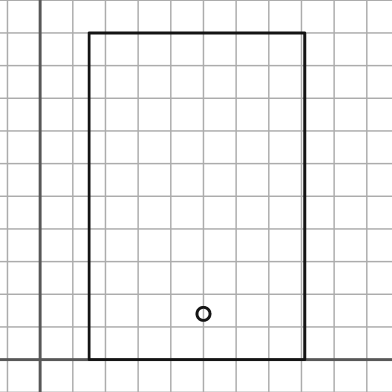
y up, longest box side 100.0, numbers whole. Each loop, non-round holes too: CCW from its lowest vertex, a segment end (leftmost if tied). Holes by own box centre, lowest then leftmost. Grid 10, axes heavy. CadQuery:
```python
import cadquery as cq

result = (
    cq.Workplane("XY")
    .moveTo(15.0, 0.0)
    .lineTo(81.0, 0.0)
    .lineTo(81.0, 100.0)
    .lineTo(15.0, 100.0)
    .close()
    .moveTo(50.0, 14.0)
    .circle(2.0)
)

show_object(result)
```